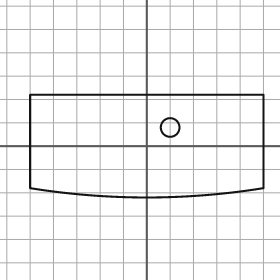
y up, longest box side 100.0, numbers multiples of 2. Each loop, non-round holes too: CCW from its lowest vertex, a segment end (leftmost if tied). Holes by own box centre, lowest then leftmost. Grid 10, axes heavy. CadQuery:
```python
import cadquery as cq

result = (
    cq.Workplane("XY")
    .moveTo(-50.0, -18.0)
    .threePointArc((0.0, -22.0), (50.0, -18.0))
    .lineTo(50.0, 22.0)
    .lineTo(-50.0, 22.0)
    .close()
    .moveTo(10.0, 8.0)
    .circle(4.0)
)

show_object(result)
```